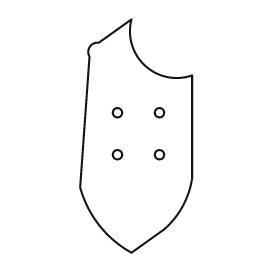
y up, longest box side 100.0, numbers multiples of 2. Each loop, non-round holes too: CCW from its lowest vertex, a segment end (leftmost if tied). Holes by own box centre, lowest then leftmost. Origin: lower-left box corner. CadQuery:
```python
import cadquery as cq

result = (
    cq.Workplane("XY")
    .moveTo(22.0, 0.0)
    .lineTo(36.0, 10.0)
    .threePointArc((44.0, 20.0), (48.0, 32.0))
    .lineTo(48.0, 76.0)
    .threePointArc((28.0, 80.0), (22.0, 100.0))
    .lineTo(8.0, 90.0)
    .threePointArc((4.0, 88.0), (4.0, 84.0))
    .lineTo(0.0, 28.0)
    .threePointArc((8.0, 12.0), (22.0, 0.0))
    .close()
    .moveTo(16.0, 42.0)
    .circle(2.0)
    .moveTo(34.0, 42.0)
    .circle(2.0)
    .moveTo(16.0, 60.0)
    .circle(2.0)
    .moveTo(34.0, 60.0)
    .circle(2.0)
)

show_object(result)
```